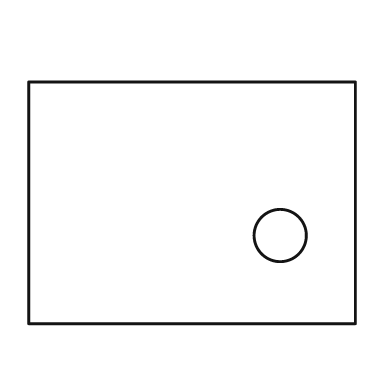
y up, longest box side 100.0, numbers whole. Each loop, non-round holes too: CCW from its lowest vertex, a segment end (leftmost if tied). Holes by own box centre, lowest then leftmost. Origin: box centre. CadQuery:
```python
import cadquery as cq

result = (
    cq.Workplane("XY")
    .moveTo(-50.0, -37.0)
    .lineTo(50.0, -37.0)
    .lineTo(50.0, 37.0)
    .lineTo(-50.0, 37.0)
    .close()
    .moveTo(27.0, -10.0)
    .circle(8.0)
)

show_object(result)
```